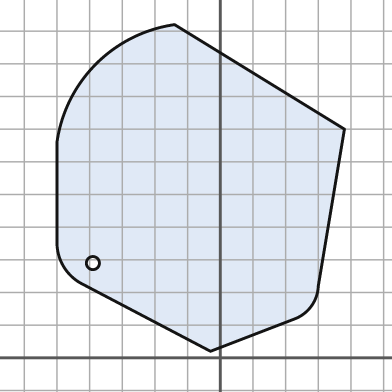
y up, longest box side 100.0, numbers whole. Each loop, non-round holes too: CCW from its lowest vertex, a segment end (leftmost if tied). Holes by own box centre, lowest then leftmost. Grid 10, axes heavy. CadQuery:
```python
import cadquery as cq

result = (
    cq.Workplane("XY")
    .moveTo(-3.0, 2.0)
    .lineTo(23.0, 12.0)
    .threePointArc((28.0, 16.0), (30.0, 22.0))
    .lineTo(38.0, 70.0)
    .lineTo(-14.0, 102.0)
    .threePointArc((-38.0, 90.0), (-50.0, 66.0))
    .lineTo(-50.0, 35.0)
    .threePointArc((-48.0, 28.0), (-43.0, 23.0))
    .close()
    .moveTo(-39.0, 29.0)
    .circle(2.0)
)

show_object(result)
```